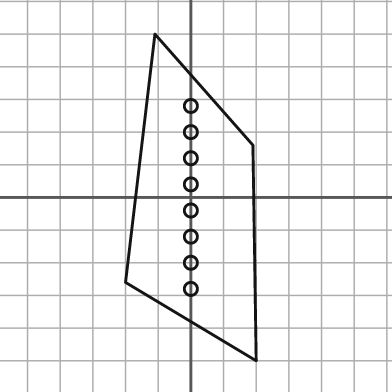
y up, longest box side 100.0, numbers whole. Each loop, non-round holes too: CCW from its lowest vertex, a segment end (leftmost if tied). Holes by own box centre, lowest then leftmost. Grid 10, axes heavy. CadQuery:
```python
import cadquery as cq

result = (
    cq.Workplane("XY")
    .moveTo(20.0, -50.0)
    .lineTo(19.0, 16.0)
    .lineTo(-11.0, 50.0)
    .lineTo(-20.0, -26.0)
    .close()
    .moveTo(0.0, -28.0)
    .circle(2.0)
    .moveTo(0.0, -20.0)
    .circle(2.0)
    .moveTo(0.0, -12.0)
    .circle(2.0)
    .moveTo(0.0, -4.0)
    .circle(2.0)
    .moveTo(0.0, 4.0)
    .circle(2.0)
    .moveTo(0.0, 12.0)
    .circle(2.0)
    .moveTo(0.0, 20.0)
    .circle(2.0)
    .moveTo(0.0, 28.0)
    .circle(2.0)
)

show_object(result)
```